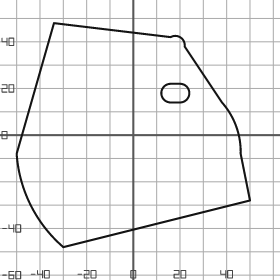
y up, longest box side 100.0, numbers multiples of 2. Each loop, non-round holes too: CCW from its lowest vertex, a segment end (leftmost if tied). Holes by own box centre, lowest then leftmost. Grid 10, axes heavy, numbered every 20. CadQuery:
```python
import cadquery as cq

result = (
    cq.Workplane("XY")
    .moveTo(-30.0, -48.0)
    .lineTo(50.0, -28.0)
    .lineTo(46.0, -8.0)
    .threePointArc((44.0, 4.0), (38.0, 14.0))
    .lineTo(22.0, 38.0)
    .threePointArc((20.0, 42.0), (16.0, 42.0))
    .lineTo(-34.0, 48.0)
    .lineTo(-50.0, -8.0)
    .threePointArc((-44.0, -30.0), (-30.0, -48.0))
    .close()
    .moveTo(16.0, 14.0)
    .lineTo(20.0, 14.0)
    .threePointArc((24.0, 18.0), (20.0, 22.0))
    .lineTo(16.0, 22.0)
    .threePointArc((12.0, 18.0), (16.0, 14.0))
    .close()
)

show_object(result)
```